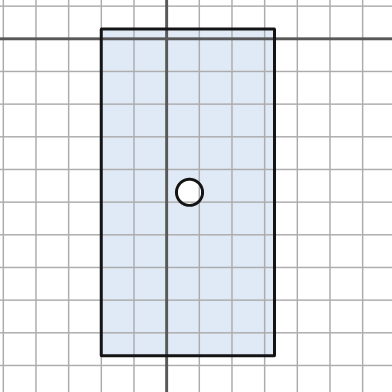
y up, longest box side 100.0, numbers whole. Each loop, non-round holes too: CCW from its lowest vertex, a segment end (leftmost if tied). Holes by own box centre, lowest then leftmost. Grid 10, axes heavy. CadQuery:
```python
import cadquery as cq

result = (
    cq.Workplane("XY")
    .moveTo(-20.0, -97.0)
    .lineTo(33.0, -97.0)
    .lineTo(33.0, 3.0)
    .lineTo(-20.0, 3.0)
    .close()
    .moveTo(7.0, -47.0)
    .circle(4.0)
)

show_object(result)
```